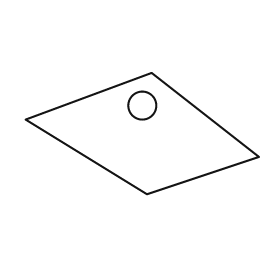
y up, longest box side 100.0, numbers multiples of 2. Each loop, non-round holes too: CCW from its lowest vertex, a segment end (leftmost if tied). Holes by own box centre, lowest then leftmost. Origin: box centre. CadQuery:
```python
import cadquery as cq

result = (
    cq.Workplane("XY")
    .moveTo(2.0, -26.0)
    .lineTo(50.0, -10.0)
    .lineTo(4.0, 26.0)
    .lineTo(-50.0, 6.0)
    .close()
    .moveTo(0.0, 12.0)
    .circle(6.0)
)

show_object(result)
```